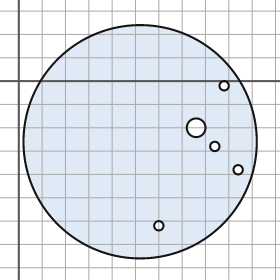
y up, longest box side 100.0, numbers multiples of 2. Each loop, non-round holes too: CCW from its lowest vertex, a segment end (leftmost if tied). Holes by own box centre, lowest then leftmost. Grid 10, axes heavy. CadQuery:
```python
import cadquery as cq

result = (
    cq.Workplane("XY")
    .moveTo(52.0, -26.0)
    .circle(50.0)
    .moveTo(60.0, -62.0)
    .circle(2.0)
    .moveTo(94.0, -38.0)
    .circle(2.0)
    .moveTo(84.0, -28.0)
    .circle(2.0)
    .moveTo(76.0, -20.0)
    .circle(4.0)
    .moveTo(88.0, -2.0)
    .circle(2.0)
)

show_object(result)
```